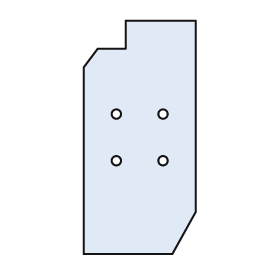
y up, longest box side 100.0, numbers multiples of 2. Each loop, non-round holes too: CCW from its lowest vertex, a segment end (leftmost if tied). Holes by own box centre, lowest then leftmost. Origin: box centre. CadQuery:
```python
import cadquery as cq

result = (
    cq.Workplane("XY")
    .moveTo(-24.0, -50.0)
    .lineTo(14.0, -50.0)
    .lineTo(24.0, -32.0)
    .lineTo(24.0, 50.0)
    .lineTo(-6.0, 50.0)
    .lineTo(-6.0, 38.0)
    .lineTo(-18.0, 38.0)
    .lineTo(-24.0, 30.0)
    .close()
    .moveTo(-10.0, -10.0)
    .circle(2.0)
    .moveTo(10.0, -10.0)
    .circle(2.0)
    .moveTo(-10.0, 10.0)
    .circle(2.0)
    .moveTo(10.0, 10.0)
    .circle(2.0)
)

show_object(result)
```